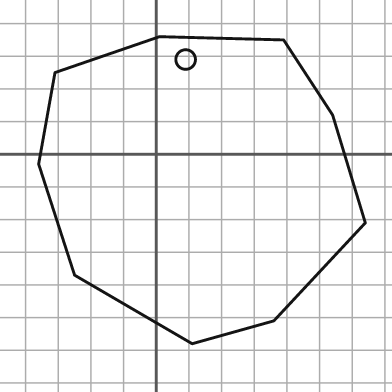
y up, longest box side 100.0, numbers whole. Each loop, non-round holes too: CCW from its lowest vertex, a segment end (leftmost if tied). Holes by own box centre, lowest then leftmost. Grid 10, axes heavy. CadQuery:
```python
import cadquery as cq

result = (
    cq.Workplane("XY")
    .moveTo(11.0, -58.0)
    .lineTo(36.0, -51.0)
    .lineTo(64.0, -21.0)
    .lineTo(54.0, 12.0)
    .lineTo(39.0, 35.0)
    .lineTo(1.0, 36.0)
    .lineTo(-31.0, 25.0)
    .lineTo(-36.0, -3.0)
    .lineTo(-25.0, -37.0)
    .close()
    .moveTo(9.0, 29.0)
    .circle(3.0)
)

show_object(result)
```